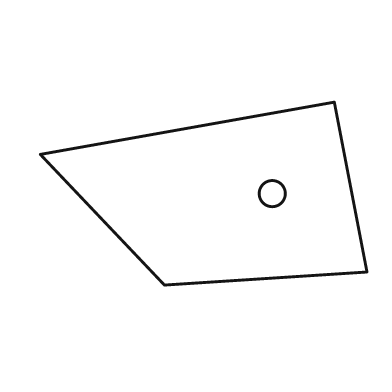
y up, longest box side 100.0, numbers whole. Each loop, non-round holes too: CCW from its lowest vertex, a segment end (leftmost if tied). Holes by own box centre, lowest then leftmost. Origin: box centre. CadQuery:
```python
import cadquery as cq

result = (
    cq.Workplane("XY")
    .moveTo(-12.0, -28.0)
    .lineTo(50.0, -24.0)
    .lineTo(40.0, 28.0)
    .lineTo(-50.0, 12.0)
    .close()
    .moveTo(21.0, 0.0)
    .circle(4.0)
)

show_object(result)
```